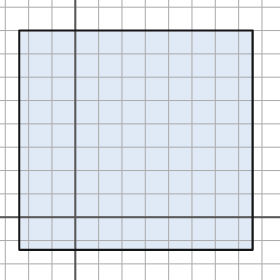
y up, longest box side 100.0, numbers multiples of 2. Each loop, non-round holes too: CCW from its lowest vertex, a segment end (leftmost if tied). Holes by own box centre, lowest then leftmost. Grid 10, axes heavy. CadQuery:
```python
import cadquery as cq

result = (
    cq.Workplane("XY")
    .moveTo(-24.0, -14.0)
    .lineTo(76.0, -14.0)
    .lineTo(76.0, 80.0)
    .lineTo(-24.0, 80.0)
    .close()
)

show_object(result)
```